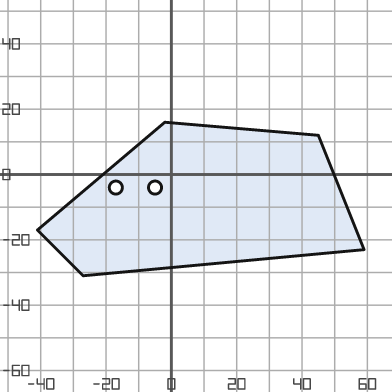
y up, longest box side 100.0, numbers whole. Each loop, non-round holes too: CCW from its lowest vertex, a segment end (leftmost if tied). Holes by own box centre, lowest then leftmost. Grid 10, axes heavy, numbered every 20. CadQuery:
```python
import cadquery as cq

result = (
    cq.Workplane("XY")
    .moveTo(-27.0, -31.0)
    .lineTo(59.0, -23.0)
    .lineTo(45.0, 12.0)
    .lineTo(-2.0, 16.0)
    .lineTo(-41.0, -17.0)
    .close()
    .moveTo(-17.0, -4.0)
    .circle(2.0)
    .moveTo(-5.0, -4.0)
    .circle(2.0)
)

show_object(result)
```